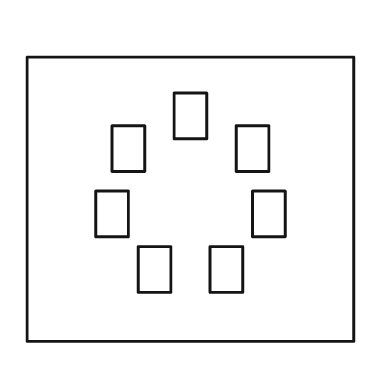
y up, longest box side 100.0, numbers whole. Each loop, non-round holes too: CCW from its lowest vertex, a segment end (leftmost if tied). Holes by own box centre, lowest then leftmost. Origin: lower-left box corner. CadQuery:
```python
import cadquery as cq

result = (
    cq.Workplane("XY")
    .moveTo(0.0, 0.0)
    .lineTo(100.0, 0.0)
    .lineTo(100.0, 87.0)
    .lineTo(0.0, 87.0)
    .close()
    .moveTo(34.0, 15.0)
    .lineTo(44.0, 15.0)
    .lineTo(44.0, 29.0)
    .lineTo(34.0, 29.0)
    .close()
    .moveTo(56.0, 15.0)
    .lineTo(66.0, 15.0)
    .lineTo(66.0, 29.0)
    .lineTo(56.0, 29.0)
    .close()
    .moveTo(21.0, 32.0)
    .lineTo(31.0, 32.0)
    .lineTo(31.0, 46.0)
    .lineTo(21.0, 46.0)
    .close()
    .moveTo(69.0, 32.0)
    .lineTo(79.0, 32.0)
    .lineTo(79.0, 46.0)
    .lineTo(69.0, 46.0)
    .close()
    .moveTo(26.0, 52.0)
    .lineTo(36.0, 52.0)
    .lineTo(36.0, 66.0)
    .lineTo(26.0, 66.0)
    .close()
    .moveTo(64.0, 52.0)
    .lineTo(74.0, 52.0)
    .lineTo(74.0, 66.0)
    .lineTo(64.0, 66.0)
    .close()
    .moveTo(45.0, 62.0)
    .lineTo(55.0, 62.0)
    .lineTo(55.0, 76.0)
    .lineTo(45.0, 76.0)
    .close()
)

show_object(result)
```